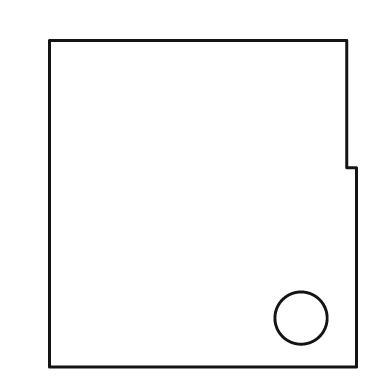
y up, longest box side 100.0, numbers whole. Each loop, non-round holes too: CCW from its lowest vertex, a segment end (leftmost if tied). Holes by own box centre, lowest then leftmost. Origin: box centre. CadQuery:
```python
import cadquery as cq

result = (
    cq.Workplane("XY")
    .moveTo(-47.0, -50.0)
    .lineTo(47.0, -50.0)
    .lineTo(47.0, 11.0)
    .lineTo(44.0, 11.0)
    .lineTo(44.0, 50.0)
    .lineTo(-47.0, 50.0)
    .close()
    .moveTo(30.0, -35.0)
    .circle(8.0)
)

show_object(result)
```